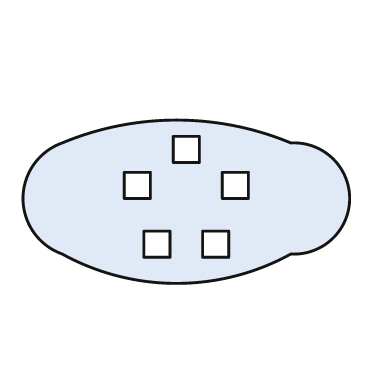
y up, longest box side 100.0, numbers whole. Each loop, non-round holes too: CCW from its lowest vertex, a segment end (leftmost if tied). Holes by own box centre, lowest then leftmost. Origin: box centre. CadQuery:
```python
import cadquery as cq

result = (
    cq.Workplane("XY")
    .moveTo(-38.0, -16.0)
    .threePointArc((-3.0, -25.0), (32.0, -16.0))
    .threePointArc((50.0, 1.0), (32.0, 18.0))
    .threePointArc((-3.0, 25.0), (-38.0, 18.0))
    .threePointArc((-50.0, 1.0), (-38.0, -16.0))
    .close()
    .moveTo(-13.0, -17.0)
    .lineTo(-5.0, -17.0)
    .lineTo(-5.0, -9.0)
    .lineTo(-13.0, -9.0)
    .close()
    .moveTo(5.0, -17.0)
    .lineTo(13.0, -17.0)
    .lineTo(13.0, -9.0)
    .lineTo(5.0, -9.0)
    .close()
    .moveTo(-19.0, 1.0)
    .lineTo(-11.0, 1.0)
    .lineTo(-11.0, 9.0)
    .lineTo(-19.0, 9.0)
    .close()
    .moveTo(11.0, 1.0)
    .lineTo(19.0, 1.0)
    .lineTo(19.0, 9.0)
    .lineTo(11.0, 9.0)
    .close()
    .moveTo(-4.0, 12.0)
    .lineTo(4.0, 12.0)
    .lineTo(4.0, 20.0)
    .lineTo(-4.0, 20.0)
    .close()
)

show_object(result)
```